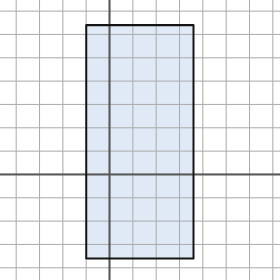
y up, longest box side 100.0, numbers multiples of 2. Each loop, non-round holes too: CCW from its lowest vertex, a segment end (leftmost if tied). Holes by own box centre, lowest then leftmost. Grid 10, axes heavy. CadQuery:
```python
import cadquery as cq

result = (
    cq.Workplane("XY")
    .moveTo(-10.0, -36.0)
    .lineTo(36.0, -36.0)
    .lineTo(36.0, 64.0)
    .lineTo(-10.0, 64.0)
    .close()
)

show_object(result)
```